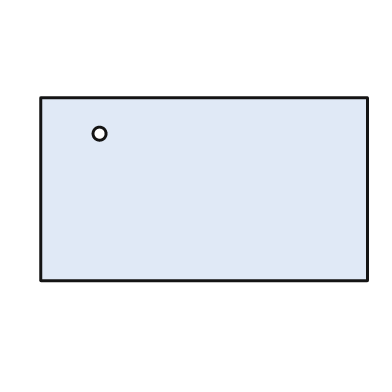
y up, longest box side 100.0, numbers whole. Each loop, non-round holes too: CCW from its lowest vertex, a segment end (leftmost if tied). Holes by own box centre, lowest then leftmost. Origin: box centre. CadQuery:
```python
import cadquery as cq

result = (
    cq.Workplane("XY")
    .moveTo(-50.0, -28.0)
    .lineTo(50.0, -28.0)
    .lineTo(50.0, 28.0)
    .lineTo(-50.0, 28.0)
    .close()
    .moveTo(-32.0, 17.0)
    .circle(2.0)
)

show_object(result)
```